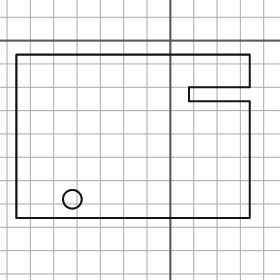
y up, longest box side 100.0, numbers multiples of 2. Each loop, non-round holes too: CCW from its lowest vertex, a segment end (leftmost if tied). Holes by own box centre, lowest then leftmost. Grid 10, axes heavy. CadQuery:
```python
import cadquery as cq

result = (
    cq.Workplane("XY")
    .moveTo(-66.0, -76.0)
    .lineTo(34.0, -76.0)
    .lineTo(34.0, -26.0)
    .lineTo(8.0, -26.0)
    .lineTo(8.0, -20.0)
    .lineTo(34.0, -20.0)
    .lineTo(34.0, -6.0)
    .lineTo(-66.0, -6.0)
    .close()
    .moveTo(-42.0, -68.0)
    .circle(4.0)
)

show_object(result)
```